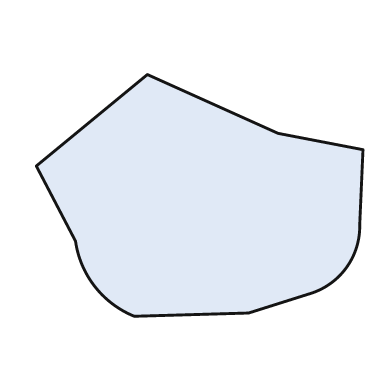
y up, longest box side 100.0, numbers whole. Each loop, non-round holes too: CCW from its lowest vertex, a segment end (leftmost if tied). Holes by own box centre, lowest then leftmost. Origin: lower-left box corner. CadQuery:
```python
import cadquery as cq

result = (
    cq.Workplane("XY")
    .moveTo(30.0, 0.0)
    .lineTo(65.0, 1.0)
    .lineTo(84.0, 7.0)
    .threePointArc((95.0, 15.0), (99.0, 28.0))
    .lineTo(100.0, 51.0)
    .lineTo(74.0, 56.0)
    .lineTo(34.0, 74.0)
    .lineTo(0.0, 46.0)
    .lineTo(12.0, 23.0)
    .threePointArc((18.0, 9.0), (30.0, 0.0))
    .close()
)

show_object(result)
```